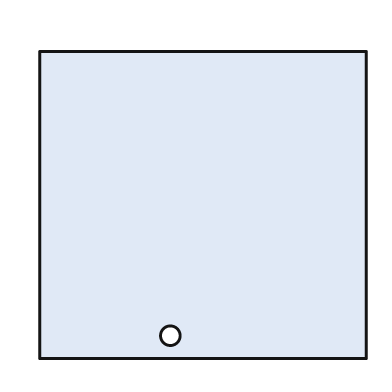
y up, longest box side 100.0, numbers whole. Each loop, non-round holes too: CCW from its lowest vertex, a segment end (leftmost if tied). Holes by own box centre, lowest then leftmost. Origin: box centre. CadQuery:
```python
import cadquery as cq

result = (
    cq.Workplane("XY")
    .moveTo(-50.0, -47.0)
    .lineTo(50.0, -47.0)
    .lineTo(50.0, 47.0)
    .lineTo(-50.0, 47.0)
    .close()
    .moveTo(-10.0, -40.0)
    .circle(3.0)
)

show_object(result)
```